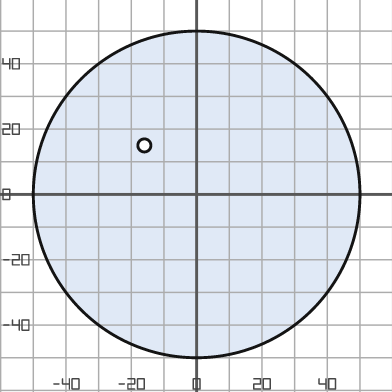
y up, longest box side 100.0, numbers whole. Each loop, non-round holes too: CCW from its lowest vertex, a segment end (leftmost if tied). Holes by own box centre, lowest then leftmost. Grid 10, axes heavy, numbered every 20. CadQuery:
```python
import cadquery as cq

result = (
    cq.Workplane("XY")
    .moveTo(0.0, 0.0)
    .circle(50.0)
    .moveTo(-16.0, 15.0)
    .circle(2.0)
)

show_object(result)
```